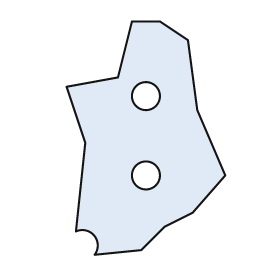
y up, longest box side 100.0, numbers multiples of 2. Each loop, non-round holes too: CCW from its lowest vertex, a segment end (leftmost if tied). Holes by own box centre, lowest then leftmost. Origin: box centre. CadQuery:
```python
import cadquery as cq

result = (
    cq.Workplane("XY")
    .moveTo(-22.0, -50.0)
    .lineTo(-2.0, -48.0)
    .lineTo(8.0, -38.0)
    .lineTo(20.0, -32.0)
    .lineTo(34.0, -16.0)
    .lineTo(22.0, 12.0)
    .lineTo(18.0, 42.0)
    .lineTo(6.0, 50.0)
    .lineTo(-6.0, 50.0)
    .lineTo(-12.0, 26.0)
    .lineTo(-34.0, 22.0)
    .lineTo(-26.0, -2.0)
    .lineTo(-30.0, -40.0)
    .threePointArc((-22.0, -42.0), (-22.0, -50.0))
    .close()
    .moveTo(0.0, -16.0)
    .circle(6.0)
    .moveTo(0.0, 18.0)
    .circle(6.0)
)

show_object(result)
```